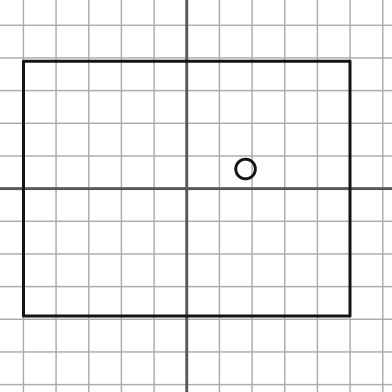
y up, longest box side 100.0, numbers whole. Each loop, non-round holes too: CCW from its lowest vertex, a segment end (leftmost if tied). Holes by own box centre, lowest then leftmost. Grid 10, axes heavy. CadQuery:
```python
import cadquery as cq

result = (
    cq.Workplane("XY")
    .moveTo(-50.0, -39.0)
    .lineTo(50.0, -39.0)
    .lineTo(50.0, 39.0)
    .lineTo(-50.0, 39.0)
    .close()
    .moveTo(18.0, 6.0)
    .circle(3.0)
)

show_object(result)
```